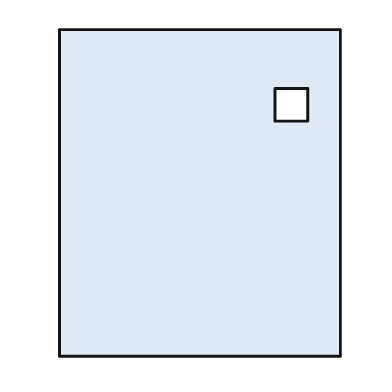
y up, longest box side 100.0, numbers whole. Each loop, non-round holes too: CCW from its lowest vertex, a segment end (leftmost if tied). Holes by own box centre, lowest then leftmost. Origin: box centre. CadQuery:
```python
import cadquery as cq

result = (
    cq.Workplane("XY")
    .moveTo(-43.0, -50.0)
    .lineTo(43.0, -50.0)
    .lineTo(43.0, 50.0)
    .lineTo(-43.0, 50.0)
    .close()
    .moveTo(23.0, 22.0)
    .lineTo(33.0, 22.0)
    .lineTo(33.0, 32.0)
    .lineTo(23.0, 32.0)
    .close()
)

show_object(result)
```